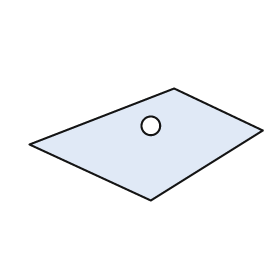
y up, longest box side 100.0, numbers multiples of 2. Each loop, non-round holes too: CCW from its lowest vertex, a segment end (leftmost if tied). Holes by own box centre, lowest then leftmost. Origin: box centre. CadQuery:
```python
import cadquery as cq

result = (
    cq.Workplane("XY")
    .moveTo(2.0, -24.0)
    .lineTo(50.0, 6.0)
    .lineTo(12.0, 24.0)
    .lineTo(-50.0, 0.0)
    .close()
    .moveTo(2.0, 8.0)
    .circle(4.0)
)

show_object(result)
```